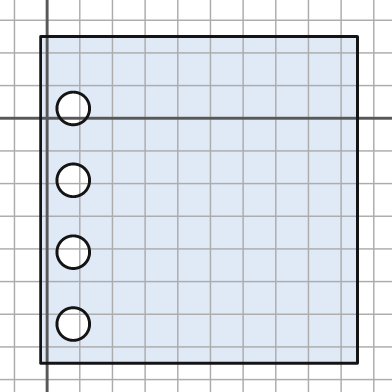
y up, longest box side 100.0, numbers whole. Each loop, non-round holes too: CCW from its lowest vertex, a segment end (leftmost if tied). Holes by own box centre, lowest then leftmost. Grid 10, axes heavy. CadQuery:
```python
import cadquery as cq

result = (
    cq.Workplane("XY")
    .moveTo(-2.0, -75.0)
    .lineTo(95.0, -75.0)
    .lineTo(95.0, 25.0)
    .lineTo(-2.0, 25.0)
    .close()
    .moveTo(8.0, -63.0)
    .circle(5.0)
    .moveTo(8.0, -41.0)
    .circle(5.0)
    .moveTo(8.0, -19.0)
    .circle(5.0)
    .moveTo(8.0, 3.0)
    .circle(5.0)
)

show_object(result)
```